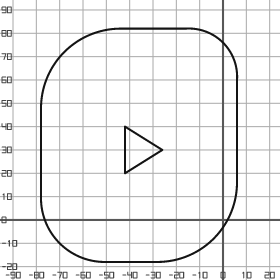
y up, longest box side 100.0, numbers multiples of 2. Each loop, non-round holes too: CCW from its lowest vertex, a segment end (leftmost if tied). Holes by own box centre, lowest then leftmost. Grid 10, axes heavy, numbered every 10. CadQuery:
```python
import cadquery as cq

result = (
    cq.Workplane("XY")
    .moveTo(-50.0, -18.0)
    .lineTo(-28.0, -18.0)
    .threePointArc((-4.0, -8.0), (6.0, 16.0))
    .lineTo(6.0, 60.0)
    .threePointArc((0.0, 76.0), (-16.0, 82.0))
    .lineTo(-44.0, 82.0)
    .threePointArc((-68.0, 72.0), (-78.0, 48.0))
    .lineTo(-78.0, 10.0)
    .threePointArc((-70.0, -10.0), (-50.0, -18.0))
    .close()
    .moveTo(-42.0, 20.0)
    .lineTo(-26.0, 30.0)
    .lineTo(-42.0, 40.0)
    .close()
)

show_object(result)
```